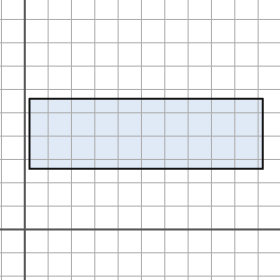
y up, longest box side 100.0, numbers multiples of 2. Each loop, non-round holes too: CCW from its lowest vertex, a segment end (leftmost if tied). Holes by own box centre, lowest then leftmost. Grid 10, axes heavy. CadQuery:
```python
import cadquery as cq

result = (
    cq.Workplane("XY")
    .moveTo(2.0, 26.0)
    .lineTo(102.0, 26.0)
    .lineTo(102.0, 56.0)
    .lineTo(2.0, 56.0)
    .close()
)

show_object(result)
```